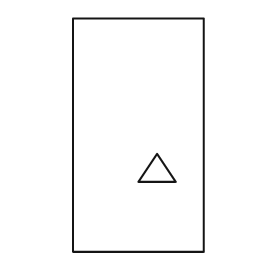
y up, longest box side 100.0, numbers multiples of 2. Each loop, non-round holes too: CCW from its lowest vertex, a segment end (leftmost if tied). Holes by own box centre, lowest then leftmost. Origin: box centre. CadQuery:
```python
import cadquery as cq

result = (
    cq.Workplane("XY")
    .moveTo(-28.0, -50.0)
    .lineTo(28.0, -50.0)
    .lineTo(28.0, 50.0)
    .lineTo(-28.0, 50.0)
    .close()
    .moveTo(0.0, -20.0)
    .lineTo(16.0, -20.0)
    .lineTo(8.0, -8.0)
    .close()
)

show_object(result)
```